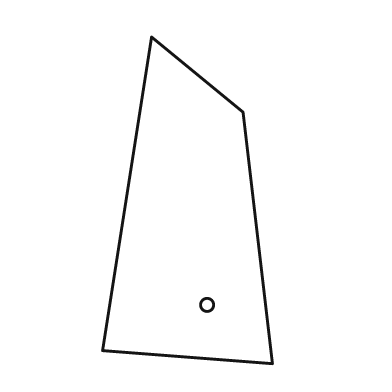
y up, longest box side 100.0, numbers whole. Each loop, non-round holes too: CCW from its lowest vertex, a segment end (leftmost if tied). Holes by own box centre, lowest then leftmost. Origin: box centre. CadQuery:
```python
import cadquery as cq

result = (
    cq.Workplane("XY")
    .moveTo(26.0, -50.0)
    .lineTo(17.0, 27.0)
    .lineTo(-11.0, 50.0)
    .lineTo(-26.0, -46.0)
    .close()
    .moveTo(6.0, -32.0)
    .circle(2.0)
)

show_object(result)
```